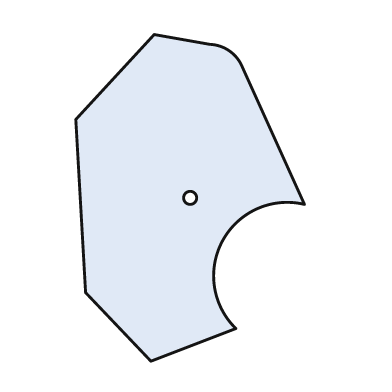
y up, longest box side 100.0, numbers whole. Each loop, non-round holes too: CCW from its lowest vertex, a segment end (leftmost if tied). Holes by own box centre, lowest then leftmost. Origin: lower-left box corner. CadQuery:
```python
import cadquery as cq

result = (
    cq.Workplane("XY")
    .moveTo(23.0, 0.0)
    .lineTo(49.0, 10.0)
    .threePointArc((45.0, 37.0), (70.0, 48.0))
    .lineTo(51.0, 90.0)
    .threePointArc((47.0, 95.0), (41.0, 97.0))
    .lineTo(24.0, 100.0)
    .lineTo(0.0, 74.0)
    .lineTo(3.0, 21.0)
    .close()
    .moveTo(35.0, 50.0)
    .circle(2.0)
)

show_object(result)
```